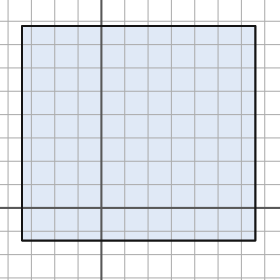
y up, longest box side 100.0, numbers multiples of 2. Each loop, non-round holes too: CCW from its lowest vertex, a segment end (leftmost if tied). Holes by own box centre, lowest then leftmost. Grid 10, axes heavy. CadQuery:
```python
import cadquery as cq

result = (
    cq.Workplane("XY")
    .moveTo(-34.0, -14.0)
    .lineTo(66.0, -14.0)
    .lineTo(66.0, 78.0)
    .lineTo(-34.0, 78.0)
    .close()
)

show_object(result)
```